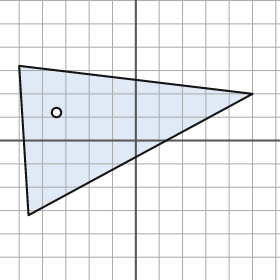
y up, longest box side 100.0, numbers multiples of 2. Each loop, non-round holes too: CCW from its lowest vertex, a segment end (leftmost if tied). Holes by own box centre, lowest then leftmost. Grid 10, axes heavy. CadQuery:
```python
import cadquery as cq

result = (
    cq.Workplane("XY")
    .moveTo(-46.0, -32.0)
    .lineTo(50.0, 20.0)
    .lineTo(-50.0, 32.0)
    .close()
    .moveTo(-34.0, 12.0)
    .circle(2.0)
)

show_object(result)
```